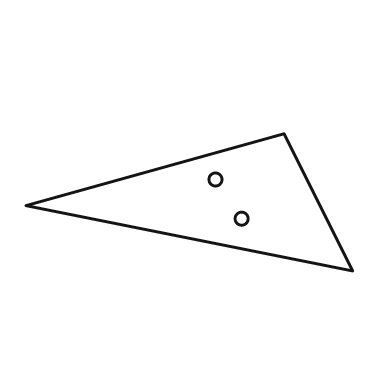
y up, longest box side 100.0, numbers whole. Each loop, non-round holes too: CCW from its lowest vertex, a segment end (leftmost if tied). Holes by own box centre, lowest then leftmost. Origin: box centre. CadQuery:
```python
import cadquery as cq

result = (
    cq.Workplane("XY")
    .moveTo(50.0, -21.0)
    .lineTo(29.0, 21.0)
    .lineTo(-50.0, -1.0)
    .close()
    .moveTo(16.0, -5.0)
    .circle(2.0)
    .moveTo(8.0, 7.0)
    .circle(2.0)
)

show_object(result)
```